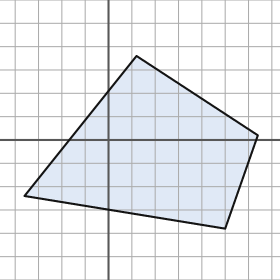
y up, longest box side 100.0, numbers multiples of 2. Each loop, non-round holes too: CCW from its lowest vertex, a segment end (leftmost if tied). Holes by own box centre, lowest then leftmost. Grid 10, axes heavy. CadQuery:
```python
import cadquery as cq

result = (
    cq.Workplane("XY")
    .moveTo(50.0, -38.0)
    .lineTo(64.0, 2.0)
    .lineTo(12.0, 36.0)
    .lineTo(-36.0, -24.0)
    .close()
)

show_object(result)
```